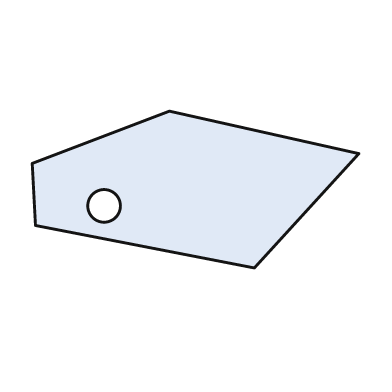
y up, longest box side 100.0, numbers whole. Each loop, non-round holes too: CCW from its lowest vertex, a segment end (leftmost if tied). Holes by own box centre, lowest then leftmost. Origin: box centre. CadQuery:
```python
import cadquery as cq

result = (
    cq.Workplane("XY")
    .moveTo(18.0, -24.0)
    .lineTo(50.0, 11.0)
    .lineTo(-8.0, 24.0)
    .lineTo(-50.0, 8.0)
    .lineTo(-49.0, -11.0)
    .close()
    .moveTo(-28.0, -5.0)
    .circle(5.0)
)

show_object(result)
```